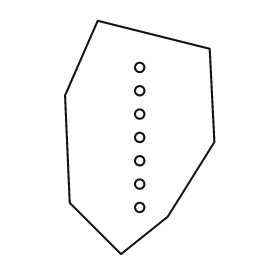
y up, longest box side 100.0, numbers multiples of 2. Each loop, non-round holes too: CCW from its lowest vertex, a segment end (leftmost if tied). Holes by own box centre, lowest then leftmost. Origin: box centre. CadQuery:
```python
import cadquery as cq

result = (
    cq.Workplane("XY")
    .moveTo(-8.0, -50.0)
    .lineTo(12.0, -34.0)
    .lineTo(32.0, -2.0)
    .lineTo(30.0, 38.0)
    .lineTo(-18.0, 50.0)
    .lineTo(-32.0, 18.0)
    .lineTo(-30.0, -28.0)
    .close()
    .moveTo(0.0, -30.0)
    .circle(2.0)
    .moveTo(0.0, -20.0)
    .circle(2.0)
    .moveTo(0.0, -10.0)
    .circle(2.0)
    .moveTo(0.0, 0.0)
    .circle(2.0)
    .moveTo(0.0, 10.0)
    .circle(2.0)
    .moveTo(0.0, 20.0)
    .circle(2.0)
    .moveTo(0.0, 30.0)
    .circle(2.0)
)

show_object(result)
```